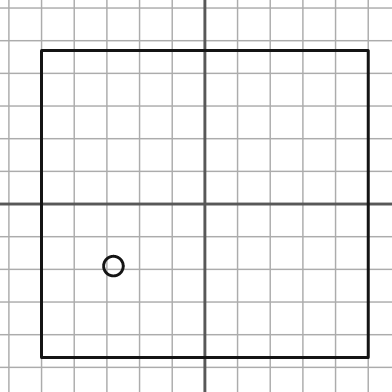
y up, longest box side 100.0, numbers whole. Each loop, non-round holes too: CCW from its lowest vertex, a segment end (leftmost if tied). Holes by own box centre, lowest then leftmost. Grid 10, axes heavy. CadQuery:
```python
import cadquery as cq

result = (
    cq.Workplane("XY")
    .moveTo(-50.0, -47.0)
    .lineTo(50.0, -47.0)
    .lineTo(50.0, 47.0)
    .lineTo(-50.0, 47.0)
    .close()
    .moveTo(-28.0, -19.0)
    .circle(3.0)
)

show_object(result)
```